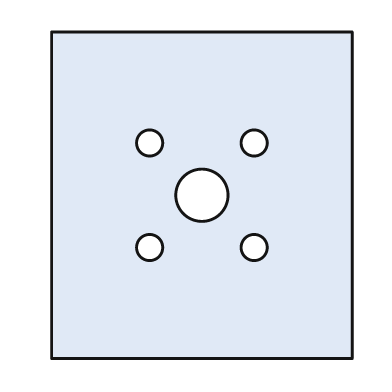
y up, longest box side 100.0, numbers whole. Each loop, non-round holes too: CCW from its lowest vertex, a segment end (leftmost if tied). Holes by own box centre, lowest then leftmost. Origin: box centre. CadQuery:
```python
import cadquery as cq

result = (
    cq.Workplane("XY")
    .moveTo(-46.0, -50.0)
    .lineTo(46.0, -50.0)
    .lineTo(46.0, 50.0)
    .lineTo(-46.0, 50.0)
    .close()
    .moveTo(-16.0, -16.0)
    .circle(4.0)
    .moveTo(16.0, -16.0)
    .circle(4.0)
    .moveTo(0.0, 0.0)
    .circle(8.0)
    .moveTo(-16.0, 16.0)
    .circle(4.0)
    .moveTo(16.0, 16.0)
    .circle(4.0)
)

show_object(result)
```